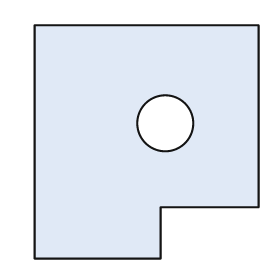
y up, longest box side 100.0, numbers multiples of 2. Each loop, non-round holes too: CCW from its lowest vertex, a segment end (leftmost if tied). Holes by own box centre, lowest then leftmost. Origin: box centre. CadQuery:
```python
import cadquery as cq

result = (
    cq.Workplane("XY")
    .moveTo(-48.0, -50.0)
    .lineTo(6.0, -50.0)
    .lineTo(6.0, -28.0)
    .lineTo(48.0, -28.0)
    .lineTo(48.0, 50.0)
    .lineTo(-48.0, 50.0)
    .close()
    .moveTo(8.0, 8.0)
    .circle(12.0)
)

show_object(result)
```